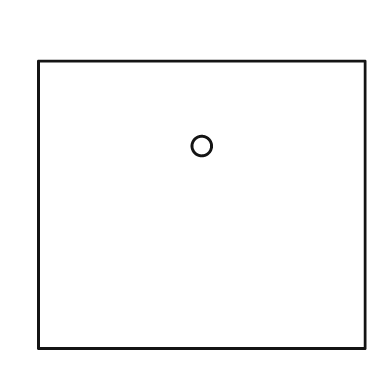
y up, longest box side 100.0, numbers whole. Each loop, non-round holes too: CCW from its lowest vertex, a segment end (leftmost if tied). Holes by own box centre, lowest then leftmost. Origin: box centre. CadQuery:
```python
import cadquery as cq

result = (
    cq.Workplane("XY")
    .moveTo(-50.0, -44.0)
    .lineTo(50.0, -44.0)
    .lineTo(50.0, 44.0)
    .lineTo(-50.0, 44.0)
    .close()
    .moveTo(0.0, 18.0)
    .circle(3.0)
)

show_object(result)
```